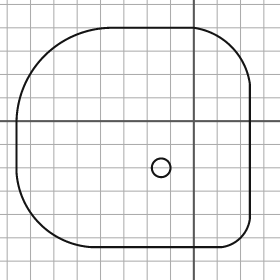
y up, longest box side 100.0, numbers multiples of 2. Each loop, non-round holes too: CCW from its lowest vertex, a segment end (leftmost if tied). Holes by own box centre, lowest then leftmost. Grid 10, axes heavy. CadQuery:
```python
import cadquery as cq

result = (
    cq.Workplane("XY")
    .moveTo(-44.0, -54.0)
    .lineTo(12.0, -54.0)
    .threePointArc((20.0, -50.0), (24.0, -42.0))
    .lineTo(24.0, 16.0)
    .threePointArc((16.0, 32.0), (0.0, 40.0))
    .lineTo(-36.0, 40.0)
    .threePointArc((-64.0, 28.0), (-76.0, 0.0))
    .lineTo(-76.0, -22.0)
    .threePointArc((-66.0, -44.0), (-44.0, -54.0))
    .close()
    .moveTo(-14.0, -20.0)
    .circle(4.0)
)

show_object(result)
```